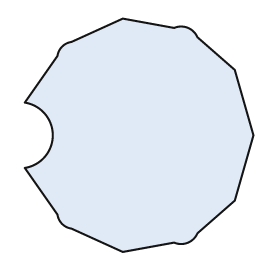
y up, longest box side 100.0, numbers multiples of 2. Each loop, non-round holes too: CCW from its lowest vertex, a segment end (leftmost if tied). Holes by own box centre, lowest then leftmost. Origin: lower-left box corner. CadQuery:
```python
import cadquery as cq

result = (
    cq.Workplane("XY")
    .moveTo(42.0, 0.0)
    .lineTo(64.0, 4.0)
    .threePointArc((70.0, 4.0), (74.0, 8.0))
    .lineTo(90.0, 22.0)
    .lineTo(98.0, 50.0)
    .lineTo(90.0, 78.0)
    .lineTo(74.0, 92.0)
    .threePointArc((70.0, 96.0), (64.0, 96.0))
    .lineTo(42.0, 100.0)
    .lineTo(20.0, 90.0)
    .threePointArc((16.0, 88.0), (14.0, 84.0))
    .lineTo(0.0, 64.0)
    .threePointArc((12.0, 50.0), (0.0, 36.0))
    .lineTo(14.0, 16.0)
    .threePointArc((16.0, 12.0), (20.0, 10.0))
    .close()
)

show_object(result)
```